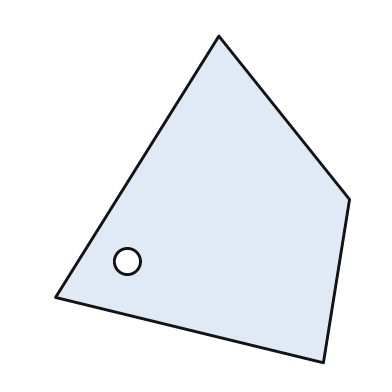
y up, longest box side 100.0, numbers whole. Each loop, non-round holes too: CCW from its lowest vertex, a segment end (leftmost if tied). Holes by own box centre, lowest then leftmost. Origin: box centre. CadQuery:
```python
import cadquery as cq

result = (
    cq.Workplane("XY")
    .moveTo(37.0, -50.0)
    .lineTo(45.0, 0.0)
    .lineTo(5.0, 50.0)
    .lineTo(-45.0, -30.0)
    .close()
    .moveTo(-23.0, -19.0)
    .circle(4.0)
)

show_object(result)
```